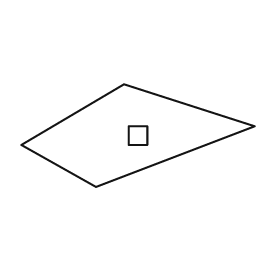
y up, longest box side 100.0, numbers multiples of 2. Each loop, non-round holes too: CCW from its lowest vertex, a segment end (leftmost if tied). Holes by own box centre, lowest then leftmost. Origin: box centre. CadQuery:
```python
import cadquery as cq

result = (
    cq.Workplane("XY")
    .moveTo(-18.0, -22.0)
    .lineTo(50.0, 4.0)
    .lineTo(-6.0, 22.0)
    .lineTo(-50.0, -4.0)
    .close()
    .moveTo(-4.0, -4.0)
    .lineTo(4.0, -4.0)
    .lineTo(4.0, 4.0)
    .lineTo(-4.0, 4.0)
    .close()
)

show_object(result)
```